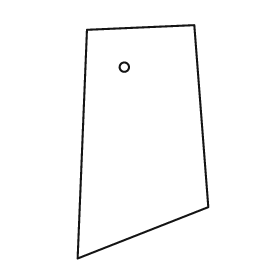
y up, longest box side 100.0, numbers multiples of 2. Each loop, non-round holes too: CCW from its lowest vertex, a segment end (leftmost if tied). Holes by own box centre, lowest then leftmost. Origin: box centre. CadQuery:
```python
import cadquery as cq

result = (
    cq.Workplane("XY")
    .moveTo(-28.0, -50.0)
    .lineTo(28.0, -28.0)
    .lineTo(22.0, 50.0)
    .lineTo(-24.0, 48.0)
    .close()
    .moveTo(-8.0, 32.0)
    .circle(2.0)
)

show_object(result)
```